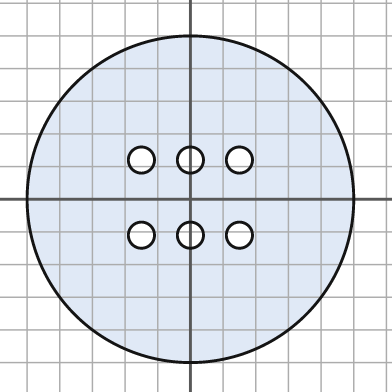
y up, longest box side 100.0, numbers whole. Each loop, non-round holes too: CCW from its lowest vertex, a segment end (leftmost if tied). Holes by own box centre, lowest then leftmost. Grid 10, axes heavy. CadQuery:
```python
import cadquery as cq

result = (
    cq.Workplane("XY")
    .moveTo(0.0, 0.0)
    .circle(50.0)
    .moveTo(-15.0, -11.0)
    .circle(4.0)
    .moveTo(0.0, -11.0)
    .circle(4.0)
    .moveTo(15.0, -11.0)
    .circle(4.0)
    .moveTo(-15.0, 12.0)
    .circle(4.0)
    .moveTo(0.0, 12.0)
    .circle(4.0)
    .moveTo(15.0, 12.0)
    .circle(4.0)
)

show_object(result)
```